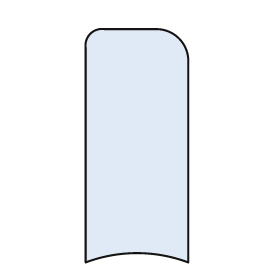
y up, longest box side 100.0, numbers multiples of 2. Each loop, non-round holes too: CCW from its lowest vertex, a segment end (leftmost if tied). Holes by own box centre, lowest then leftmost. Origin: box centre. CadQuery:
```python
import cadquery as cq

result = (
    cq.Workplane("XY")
    .moveTo(-22.0, -50.0)
    .threePointArc((0.0, -46.0), (22.0, -50.0))
    .lineTo(22.0, 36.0)
    .threePointArc((18.0, 46.0), (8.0, 50.0))
    .lineTo(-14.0, 50.0)
    .threePointArc((-20.0, 48.0), (-22.0, 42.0))
    .close()
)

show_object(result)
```